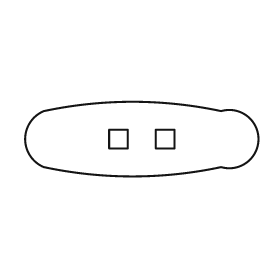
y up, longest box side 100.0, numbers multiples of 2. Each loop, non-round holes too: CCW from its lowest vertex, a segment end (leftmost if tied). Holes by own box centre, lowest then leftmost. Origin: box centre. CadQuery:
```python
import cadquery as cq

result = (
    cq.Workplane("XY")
    .moveTo(-42.0, -12.0)
    .threePointArc((-4.0, -16.0), (34.0, -12.0))
    .threePointArc((50.0, 0.0), (34.0, 12.0))
    .threePointArc((-4.0, 16.0), (-42.0, 12.0))
    .threePointArc((-50.0, 0.0), (-42.0, -12.0))
    .close()
    .moveTo(-14.0, -4.0)
    .lineTo(-6.0, -4.0)
    .lineTo(-6.0, 4.0)
    .lineTo(-14.0, 4.0)
    .close()
    .moveTo(6.0, -4.0)
    .lineTo(14.0, -4.0)
    .lineTo(14.0, 4.0)
    .lineTo(6.0, 4.0)
    .close()
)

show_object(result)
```